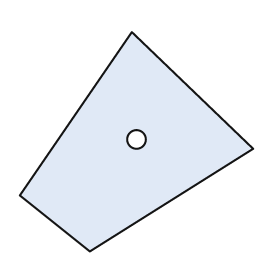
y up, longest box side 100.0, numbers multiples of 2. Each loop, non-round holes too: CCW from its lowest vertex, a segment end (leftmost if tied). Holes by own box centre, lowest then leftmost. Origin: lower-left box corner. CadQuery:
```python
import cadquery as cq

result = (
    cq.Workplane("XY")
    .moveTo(30.0, 0.0)
    .lineTo(100.0, 44.0)
    .lineTo(48.0, 94.0)
    .lineTo(0.0, 24.0)
    .close()
    .moveTo(50.0, 48.0)
    .circle(4.0)
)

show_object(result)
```